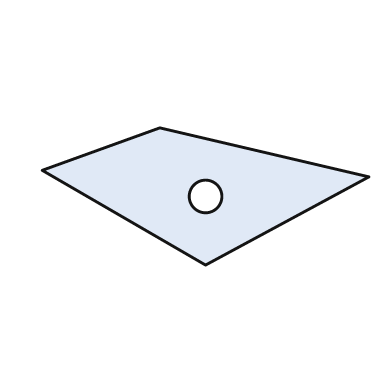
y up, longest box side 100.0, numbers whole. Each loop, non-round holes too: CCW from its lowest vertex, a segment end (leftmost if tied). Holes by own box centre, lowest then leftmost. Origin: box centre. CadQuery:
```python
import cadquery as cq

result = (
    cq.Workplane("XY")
    .moveTo(0.0, -21.0)
    .lineTo(50.0, 6.0)
    .lineTo(-14.0, 21.0)
    .lineTo(-50.0, 8.0)
    .close()
    .moveTo(0.0, 0.0)
    .circle(5.0)
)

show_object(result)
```